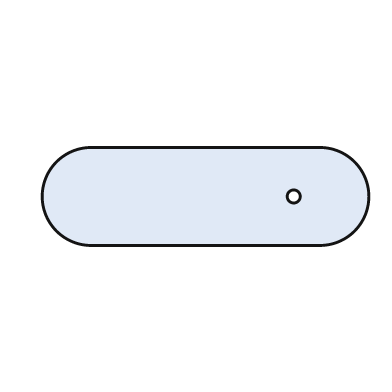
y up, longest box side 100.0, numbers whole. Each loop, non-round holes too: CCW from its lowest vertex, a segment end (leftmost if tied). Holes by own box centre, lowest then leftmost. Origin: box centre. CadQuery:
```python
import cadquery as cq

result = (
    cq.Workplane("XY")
    .moveTo(-35.0, -15.0)
    .lineTo(35.0, -15.0)
    .threePointArc((50.0, 0.0), (35.0, 15.0))
    .lineTo(-35.0, 15.0)
    .threePointArc((-50.0, 0.0), (-35.0, -15.0))
    .close()
    .moveTo(27.0, 0.0)
    .circle(2.0)
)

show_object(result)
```